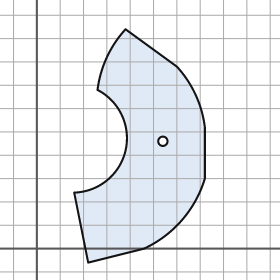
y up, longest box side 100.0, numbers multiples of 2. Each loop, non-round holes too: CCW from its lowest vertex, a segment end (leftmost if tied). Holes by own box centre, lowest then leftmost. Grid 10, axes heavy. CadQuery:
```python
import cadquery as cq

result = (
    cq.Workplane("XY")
    .moveTo(22.0, -6.0)
    .lineTo(46.0, 0.0)
    .threePointArc((62.0, 12.0), (72.0, 30.0))
    .lineTo(72.0, 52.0)
    .threePointArc((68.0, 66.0), (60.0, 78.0))
    .lineTo(38.0, 94.0)
    .threePointArc((30.0, 82.0), (26.0, 68.0))
    .threePointArc((38.0, 42.0), (16.0, 24.0))
    .close()
    .moveTo(54.0, 46.0)
    .circle(2.0)
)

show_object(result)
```